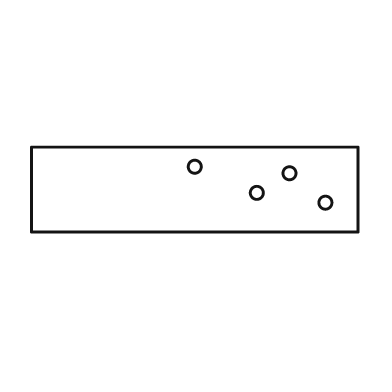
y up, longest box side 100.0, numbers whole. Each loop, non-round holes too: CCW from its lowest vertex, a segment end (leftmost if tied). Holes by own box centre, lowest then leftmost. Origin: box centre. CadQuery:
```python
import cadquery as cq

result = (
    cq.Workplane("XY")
    .moveTo(-50.0, -13.0)
    .lineTo(50.0, -13.0)
    .lineTo(50.0, 13.0)
    .lineTo(-50.0, 13.0)
    .close()
    .moveTo(40.0, -4.0)
    .circle(2.0)
    .moveTo(19.0, -1.0)
    .circle(2.0)
    .moveTo(29.0, 5.0)
    .circle(2.0)
    .moveTo(0.0, 7.0)
    .circle(2.0)
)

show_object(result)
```